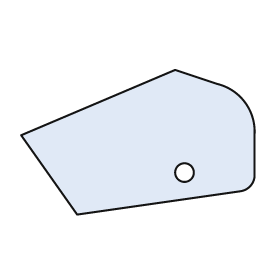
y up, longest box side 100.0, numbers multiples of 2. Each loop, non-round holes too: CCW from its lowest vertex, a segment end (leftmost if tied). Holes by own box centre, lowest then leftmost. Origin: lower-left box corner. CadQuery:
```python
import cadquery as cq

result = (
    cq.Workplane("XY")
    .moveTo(24.0, 0.0)
    .lineTo(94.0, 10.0)
    .threePointArc((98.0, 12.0), (100.0, 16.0))
    .lineTo(100.0, 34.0)
    .threePointArc((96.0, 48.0), (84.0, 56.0))
    .lineTo(66.0, 62.0)
    .lineTo(0.0, 34.0)
    .close()
    .moveTo(70.0, 18.0)
    .circle(4.0)
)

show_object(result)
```